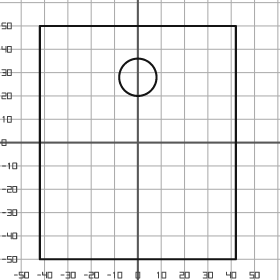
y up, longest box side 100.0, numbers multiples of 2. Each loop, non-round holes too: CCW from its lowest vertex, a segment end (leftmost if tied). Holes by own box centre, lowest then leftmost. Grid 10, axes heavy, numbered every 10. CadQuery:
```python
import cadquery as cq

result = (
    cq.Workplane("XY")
    .moveTo(-42.0, -50.0)
    .lineTo(42.0, -50.0)
    .lineTo(42.0, 50.0)
    .lineTo(-42.0, 50.0)
    .close()
    .moveTo(0.0, 28.0)
    .circle(8.0)
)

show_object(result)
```